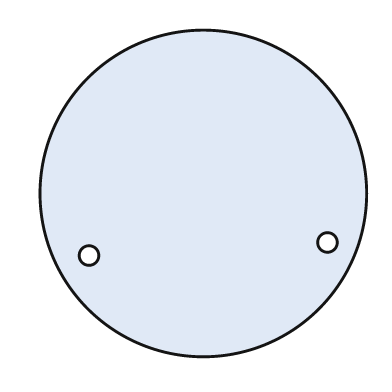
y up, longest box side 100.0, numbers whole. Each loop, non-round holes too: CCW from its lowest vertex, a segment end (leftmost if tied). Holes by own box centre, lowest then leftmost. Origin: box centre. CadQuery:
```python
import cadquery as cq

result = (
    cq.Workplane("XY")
    .moveTo(0.0, 0.0)
    .circle(50.0)
    .moveTo(-35.0, -19.0)
    .circle(3.0)
    .moveTo(38.0, -15.0)
    .circle(3.0)
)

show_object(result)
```